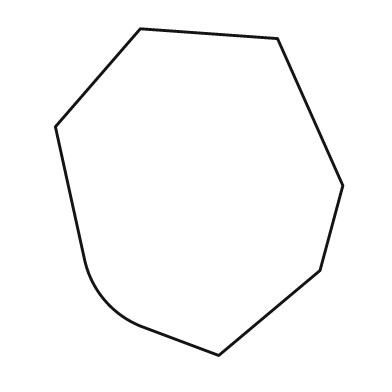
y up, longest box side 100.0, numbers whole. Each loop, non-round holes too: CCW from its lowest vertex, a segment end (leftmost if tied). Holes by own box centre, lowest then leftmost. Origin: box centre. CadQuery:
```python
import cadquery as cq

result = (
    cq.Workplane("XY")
    .moveTo(6.0, -50.0)
    .lineTo(37.0, -24.0)
    .lineTo(44.0, 2.0)
    .lineTo(24.0, 47.0)
    .lineTo(-18.0, 50.0)
    .lineTo(-44.0, 20.0)
    .lineTo(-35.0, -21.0)
    .threePointArc((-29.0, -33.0), (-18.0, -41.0))
    .close()
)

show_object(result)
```